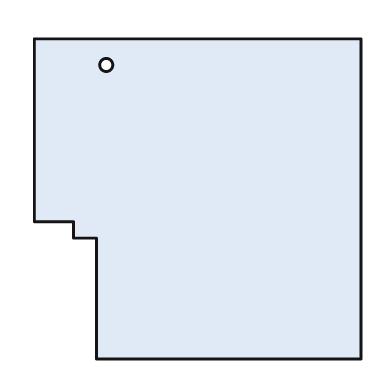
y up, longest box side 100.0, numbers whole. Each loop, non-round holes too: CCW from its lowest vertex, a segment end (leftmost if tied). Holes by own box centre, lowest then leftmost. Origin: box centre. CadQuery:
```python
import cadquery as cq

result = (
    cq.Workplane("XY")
    .moveTo(-31.0, -49.0)
    .lineTo(50.0, -49.0)
    .lineTo(50.0, 49.0)
    .lineTo(-50.0, 49.0)
    .lineTo(-50.0, -7.0)
    .lineTo(-38.0, -7.0)
    .lineTo(-38.0, -12.0)
    .lineTo(-31.0, -12.0)
    .close()
    .moveTo(-28.0, 41.0)
    .circle(2.0)
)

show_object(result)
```